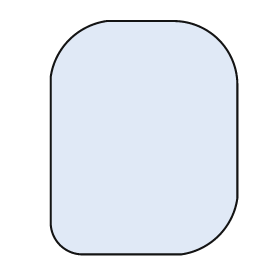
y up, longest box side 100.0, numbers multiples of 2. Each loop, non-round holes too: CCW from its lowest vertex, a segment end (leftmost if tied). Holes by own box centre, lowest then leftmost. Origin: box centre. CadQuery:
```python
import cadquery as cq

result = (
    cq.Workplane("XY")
    .moveTo(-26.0, -50.0)
    .lineTo(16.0, -50.0)
    .threePointArc((32.0, -42.0), (40.0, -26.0))
    .lineTo(40.0, 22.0)
    .threePointArc((32.0, 42.0), (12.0, 50.0))
    .lineTo(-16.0, 50.0)
    .threePointArc((-32.0, 42.0), (-40.0, 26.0))
    .lineTo(-40.0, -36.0)
    .threePointArc((-36.0, -46.0), (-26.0, -50.0))
    .close()
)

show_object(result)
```